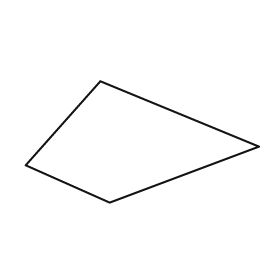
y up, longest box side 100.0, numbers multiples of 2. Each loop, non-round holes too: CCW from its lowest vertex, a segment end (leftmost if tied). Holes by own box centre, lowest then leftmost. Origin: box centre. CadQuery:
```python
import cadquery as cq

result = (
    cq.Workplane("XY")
    .moveTo(-14.0, -26.0)
    .lineTo(50.0, -2.0)
    .lineTo(-18.0, 26.0)
    .lineTo(-50.0, -10.0)
    .close()
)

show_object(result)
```